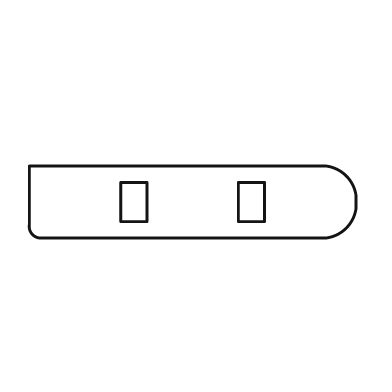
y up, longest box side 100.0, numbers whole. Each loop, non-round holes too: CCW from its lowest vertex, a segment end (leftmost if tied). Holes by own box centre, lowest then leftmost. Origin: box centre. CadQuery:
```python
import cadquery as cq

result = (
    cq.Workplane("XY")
    .moveTo(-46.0, -11.0)
    .lineTo(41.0, -11.0)
    .threePointArc((47.0, -8.0), (50.0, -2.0))
    .lineTo(50.0, 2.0)
    .threePointArc((47.0, 8.0), (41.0, 11.0))
    .lineTo(-50.0, 11.0)
    .lineTo(-50.0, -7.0)
    .threePointArc((-49.0, -10.0), (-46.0, -11.0))
    .close()
    .moveTo(-22.0, -6.0)
    .lineTo(-14.0, -6.0)
    .lineTo(-14.0, 6.0)
    .lineTo(-22.0, 6.0)
    .close()
    .moveTo(14.0, -6.0)
    .lineTo(22.0, -6.0)
    .lineTo(22.0, 6.0)
    .lineTo(14.0, 6.0)
    .close()
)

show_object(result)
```